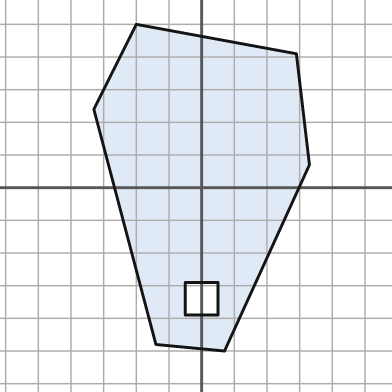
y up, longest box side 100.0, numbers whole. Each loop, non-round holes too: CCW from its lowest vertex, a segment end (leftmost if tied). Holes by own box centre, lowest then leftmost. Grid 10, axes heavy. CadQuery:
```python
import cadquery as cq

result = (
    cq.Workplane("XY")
    .moveTo(7.0, -50.0)
    .lineTo(33.0, 7.0)
    .lineTo(29.0, 41.0)
    .lineTo(-20.0, 50.0)
    .lineTo(-33.0, 24.0)
    .lineTo(-14.0, -48.0)
    .close()
    .moveTo(-5.0, -39.0)
    .lineTo(5.0, -39.0)
    .lineTo(5.0, -29.0)
    .lineTo(-5.0, -29.0)
    .close()
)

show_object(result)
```